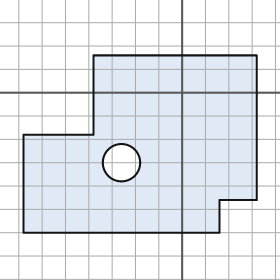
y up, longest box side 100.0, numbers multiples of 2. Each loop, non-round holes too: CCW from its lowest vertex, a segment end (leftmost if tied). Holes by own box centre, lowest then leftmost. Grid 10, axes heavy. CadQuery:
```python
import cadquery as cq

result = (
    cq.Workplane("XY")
    .moveTo(-68.0, -60.0)
    .lineTo(16.0, -60.0)
    .lineTo(16.0, -46.0)
    .lineTo(32.0, -46.0)
    .lineTo(32.0, 16.0)
    .lineTo(-38.0, 16.0)
    .lineTo(-38.0, -18.0)
    .lineTo(-68.0, -18.0)
    .close()
    .moveTo(-26.0, -30.0)
    .circle(8.0)
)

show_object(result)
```